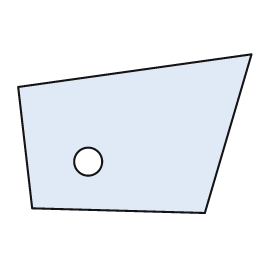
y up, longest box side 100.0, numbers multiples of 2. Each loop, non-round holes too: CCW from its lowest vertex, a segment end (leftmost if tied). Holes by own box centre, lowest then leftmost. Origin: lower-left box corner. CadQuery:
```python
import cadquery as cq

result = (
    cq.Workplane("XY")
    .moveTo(80.0, 0.0)
    .lineTo(100.0, 68.0)
    .lineTo(0.0, 54.0)
    .lineTo(6.0, 2.0)
    .close()
    .moveTo(30.0, 22.0)
    .circle(6.0)
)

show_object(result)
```